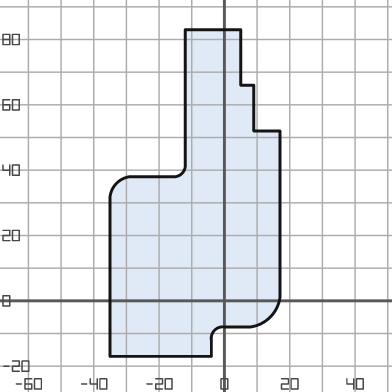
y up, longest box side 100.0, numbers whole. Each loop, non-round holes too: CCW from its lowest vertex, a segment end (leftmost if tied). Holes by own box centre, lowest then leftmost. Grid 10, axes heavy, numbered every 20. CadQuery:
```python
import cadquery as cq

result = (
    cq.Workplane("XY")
    .moveTo(-35.0, -17.0)
    .lineTo(-4.0, -17.0)
    .lineTo(-4.0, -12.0)
    .threePointArc((-3.0, -9.0), (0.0, -8.0))
    .lineTo(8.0, -8.0)
    .threePointArc((14.0, -5.0), (17.0, 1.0))
    .lineTo(17.0, 52.0)
    .lineTo(9.0, 52.0)
    .lineTo(9.0, 66.0)
    .lineTo(5.0, 66.0)
    .lineTo(5.0, 83.0)
    .lineTo(-12.0, 83.0)
    .lineTo(-12.0, 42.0)
    .threePointArc((-13.0, 39.0), (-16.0, 38.0))
    .lineTo(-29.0, 38.0)
    .threePointArc((-33.0, 36.0), (-35.0, 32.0))
    .close()
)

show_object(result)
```